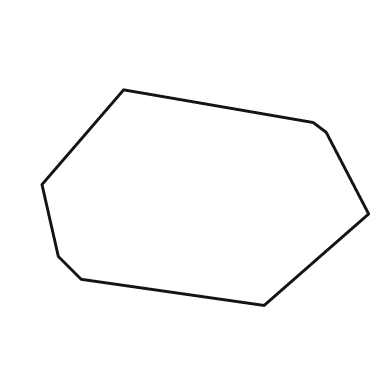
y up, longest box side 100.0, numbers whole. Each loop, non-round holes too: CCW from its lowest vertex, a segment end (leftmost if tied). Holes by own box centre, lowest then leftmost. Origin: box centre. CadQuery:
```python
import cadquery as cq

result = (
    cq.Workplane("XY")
    .moveTo(18.0, -33.0)
    .lineTo(50.0, -5.0)
    .lineTo(37.0, 20.0)
    .lineTo(33.0, 23.0)
    .lineTo(-25.0, 33.0)
    .lineTo(-50.0, 4.0)
    .lineTo(-45.0, -18.0)
    .lineTo(-38.0, -25.0)
    .close()
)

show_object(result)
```